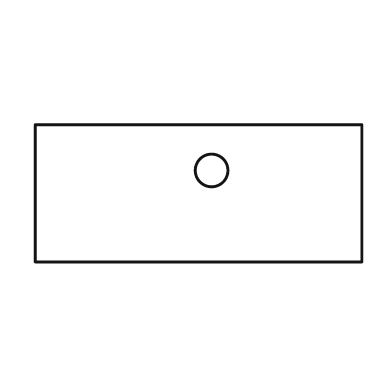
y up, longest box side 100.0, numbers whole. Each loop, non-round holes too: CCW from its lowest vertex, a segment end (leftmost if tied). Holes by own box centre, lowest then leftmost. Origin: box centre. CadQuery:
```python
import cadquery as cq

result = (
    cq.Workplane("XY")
    .moveTo(-50.0, -21.0)
    .lineTo(50.0, -21.0)
    .lineTo(50.0, 21.0)
    .lineTo(-50.0, 21.0)
    .close()
    .moveTo(4.0, 7.0)
    .circle(5.0)
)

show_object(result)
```